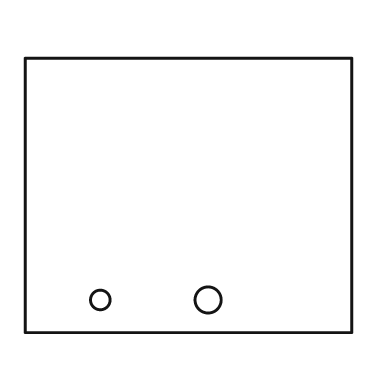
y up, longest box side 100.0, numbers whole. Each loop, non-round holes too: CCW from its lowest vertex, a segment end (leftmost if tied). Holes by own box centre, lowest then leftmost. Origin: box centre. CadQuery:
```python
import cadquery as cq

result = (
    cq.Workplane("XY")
    .moveTo(-50.0, -42.0)
    .lineTo(50.0, -42.0)
    .lineTo(50.0, 42.0)
    .lineTo(-50.0, 42.0)
    .close()
    .moveTo(-27.0, -32.0)
    .circle(3.0)
    .moveTo(6.0, -32.0)
    .circle(4.0)
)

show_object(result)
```